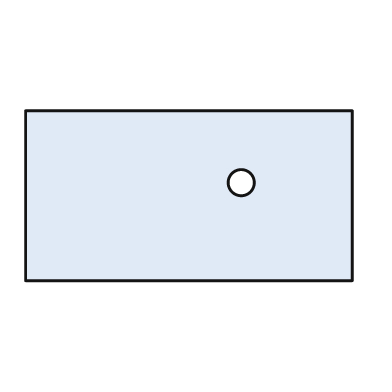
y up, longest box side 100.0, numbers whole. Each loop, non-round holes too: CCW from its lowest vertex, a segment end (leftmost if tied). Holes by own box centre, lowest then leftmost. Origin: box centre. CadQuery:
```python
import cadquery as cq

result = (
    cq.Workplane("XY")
    .moveTo(-50.0, -26.0)
    .lineTo(50.0, -26.0)
    .lineTo(50.0, 26.0)
    .lineTo(-50.0, 26.0)
    .close()
    .moveTo(16.0, 4.0)
    .circle(4.0)
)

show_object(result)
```